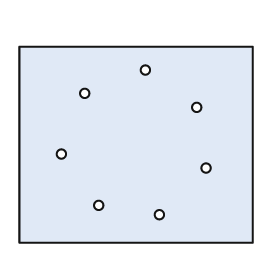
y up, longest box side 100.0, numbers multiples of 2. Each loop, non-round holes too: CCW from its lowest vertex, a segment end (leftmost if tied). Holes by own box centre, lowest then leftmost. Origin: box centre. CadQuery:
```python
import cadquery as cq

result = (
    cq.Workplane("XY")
    .moveTo(-50.0, -42.0)
    .lineTo(50.0, -42.0)
    .lineTo(50.0, 42.0)
    .lineTo(-50.0, 42.0)
    .close()
    .moveTo(10.0, -30.0)
    .circle(2.0)
    .moveTo(-16.0, -26.0)
    .circle(2.0)
    .moveTo(30.0, -10.0)
    .circle(2.0)
    .moveTo(-32.0, -4.0)
    .circle(2.0)
    .moveTo(26.0, 16.0)
    .circle(2.0)
    .moveTo(-22.0, 22.0)
    .circle(2.0)
    .moveTo(4.0, 32.0)
    .circle(2.0)
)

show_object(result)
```